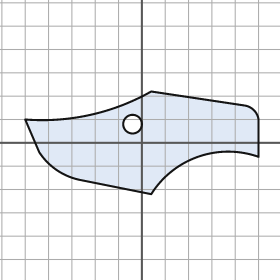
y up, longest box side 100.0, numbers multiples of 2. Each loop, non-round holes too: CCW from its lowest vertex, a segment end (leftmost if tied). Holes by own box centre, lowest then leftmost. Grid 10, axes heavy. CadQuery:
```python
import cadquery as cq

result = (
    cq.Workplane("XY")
    .moveTo(4.0, -22.0)
    .threePointArc((24.0, -6.0), (50.0, -6.0))
    .lineTo(50.0, 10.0)
    .threePointArc((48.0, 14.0), (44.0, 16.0))
    .lineTo(4.0, 22.0)
    .threePointArc((-22.0, 12.0), (-50.0, 10.0))
    .lineTo(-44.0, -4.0)
    .threePointArc((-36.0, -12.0), (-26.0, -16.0))
    .close()
    .moveTo(-4.0, 8.0)
    .circle(4.0)
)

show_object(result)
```